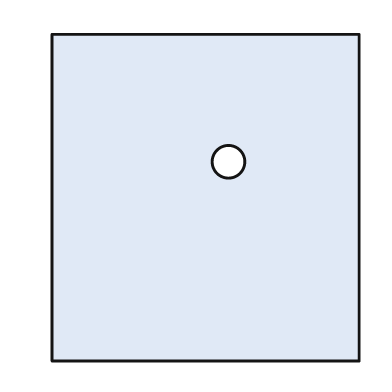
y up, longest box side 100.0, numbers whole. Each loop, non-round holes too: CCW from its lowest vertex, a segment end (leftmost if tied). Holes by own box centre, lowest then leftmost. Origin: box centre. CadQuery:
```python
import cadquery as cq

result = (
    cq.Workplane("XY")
    .moveTo(-47.0, -50.0)
    .lineTo(47.0, -50.0)
    .lineTo(47.0, 50.0)
    .lineTo(-47.0, 50.0)
    .close()
    .moveTo(7.0, 11.0)
    .circle(5.0)
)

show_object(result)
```